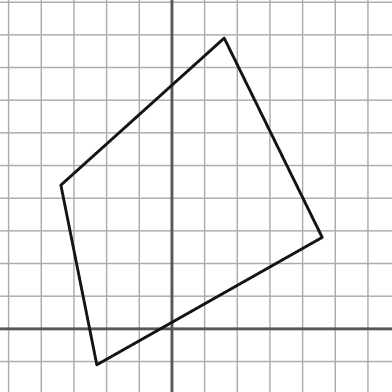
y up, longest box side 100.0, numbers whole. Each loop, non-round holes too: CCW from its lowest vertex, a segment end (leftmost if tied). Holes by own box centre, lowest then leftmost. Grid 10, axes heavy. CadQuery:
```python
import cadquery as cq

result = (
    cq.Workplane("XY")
    .moveTo(-23.0, -11.0)
    .lineTo(46.0, 28.0)
    .lineTo(16.0, 89.0)
    .lineTo(-34.0, 44.0)
    .close()
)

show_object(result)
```